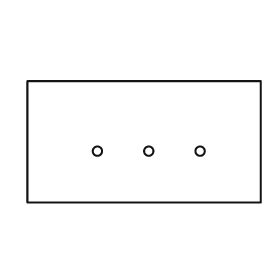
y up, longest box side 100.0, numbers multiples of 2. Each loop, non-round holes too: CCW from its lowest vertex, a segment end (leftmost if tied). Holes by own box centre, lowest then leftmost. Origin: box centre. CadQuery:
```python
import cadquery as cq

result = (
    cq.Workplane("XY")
    .moveTo(-50.0, -26.0)
    .lineTo(50.0, -26.0)
    .lineTo(50.0, 26.0)
    .lineTo(-50.0, 26.0)
    .close()
    .moveTo(-20.0, -4.0)
    .circle(2.0)
    .moveTo(2.0, -4.0)
    .circle(2.0)
    .moveTo(24.0, -4.0)
    .circle(2.0)
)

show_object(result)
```